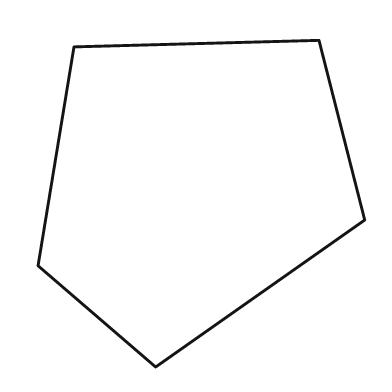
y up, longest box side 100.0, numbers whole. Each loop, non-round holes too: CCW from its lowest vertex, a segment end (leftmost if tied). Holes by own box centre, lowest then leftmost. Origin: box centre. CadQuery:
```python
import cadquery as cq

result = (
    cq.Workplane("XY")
    .moveTo(-14.0, -50.0)
    .lineTo(50.0, -5.0)
    .lineTo(36.0, 50.0)
    .lineTo(-39.0, 48.0)
    .lineTo(-50.0, -19.0)
    .close()
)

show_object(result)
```